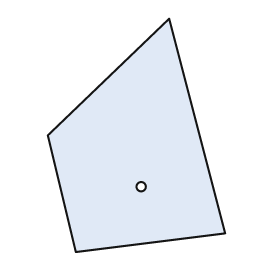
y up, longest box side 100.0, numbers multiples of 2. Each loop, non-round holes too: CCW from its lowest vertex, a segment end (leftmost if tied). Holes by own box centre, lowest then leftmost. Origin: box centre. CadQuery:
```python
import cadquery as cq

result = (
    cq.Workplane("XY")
    .moveTo(-26.0, -50.0)
    .lineTo(38.0, -42.0)
    .lineTo(14.0, 50.0)
    .lineTo(-38.0, 0.0)
    .close()
    .moveTo(2.0, -22.0)
    .circle(2.0)
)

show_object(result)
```